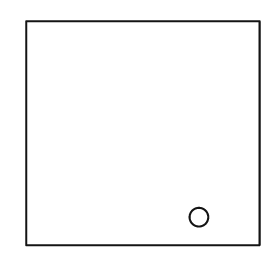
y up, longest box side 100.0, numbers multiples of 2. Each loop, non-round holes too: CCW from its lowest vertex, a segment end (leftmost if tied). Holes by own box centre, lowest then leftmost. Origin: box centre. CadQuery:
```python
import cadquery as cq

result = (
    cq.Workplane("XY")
    .moveTo(-50.0, -48.0)
    .lineTo(50.0, -48.0)
    .lineTo(50.0, 48.0)
    .lineTo(-50.0, 48.0)
    .close()
    .moveTo(24.0, -36.0)
    .circle(4.0)
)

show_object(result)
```